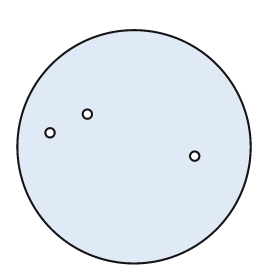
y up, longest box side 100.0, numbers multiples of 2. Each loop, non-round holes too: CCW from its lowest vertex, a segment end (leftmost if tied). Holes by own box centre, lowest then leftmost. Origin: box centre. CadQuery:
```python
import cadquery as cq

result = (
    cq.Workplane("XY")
    .moveTo(0.0, 0.0)
    .circle(50.0)
    .moveTo(26.0, -4.0)
    .circle(2.0)
    .moveTo(-36.0, 6.0)
    .circle(2.0)
    .moveTo(-20.0, 14.0)
    .circle(2.0)
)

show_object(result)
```